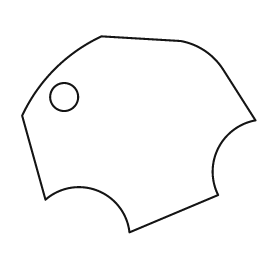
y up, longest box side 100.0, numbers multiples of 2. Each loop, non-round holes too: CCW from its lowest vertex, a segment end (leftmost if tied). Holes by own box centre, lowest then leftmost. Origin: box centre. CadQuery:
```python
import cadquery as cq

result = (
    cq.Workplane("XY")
    .moveTo(-4.0, -42.0)
    .lineTo(34.0, -26.0)
    .threePointArc((34.0, -6.0), (50.0, 6.0))
    .lineTo(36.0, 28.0)
    .threePointArc((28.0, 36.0), (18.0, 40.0))
    .lineTo(-16.0, 42.0)
    .threePointArc((-36.0, 28.0), (-50.0, 8.0))
    .lineTo(-40.0, -28.0)
    .threePointArc((-18.0, -24.0), (-4.0, -42.0))
    .close()
    .moveTo(-32.0, 16.0)
    .circle(6.0)
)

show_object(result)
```